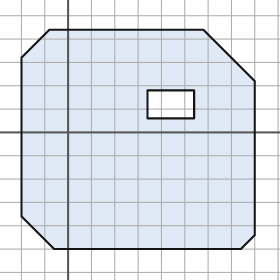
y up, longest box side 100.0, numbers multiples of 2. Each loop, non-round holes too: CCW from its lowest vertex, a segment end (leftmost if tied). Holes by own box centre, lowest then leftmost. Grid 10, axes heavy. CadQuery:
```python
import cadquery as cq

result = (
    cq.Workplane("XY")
    .moveTo(-6.0, -50.0)
    .lineTo(74.0, -50.0)
    .lineTo(80.0, -44.0)
    .lineTo(80.0, 22.0)
    .lineTo(58.0, 44.0)
    .lineTo(-8.0, 44.0)
    .lineTo(-20.0, 32.0)
    .lineTo(-20.0, -36.0)
    .close()
    .moveTo(34.0, 6.0)
    .lineTo(54.0, 6.0)
    .lineTo(54.0, 18.0)
    .lineTo(34.0, 18.0)
    .close()
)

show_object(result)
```